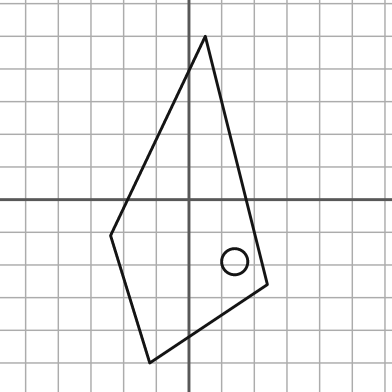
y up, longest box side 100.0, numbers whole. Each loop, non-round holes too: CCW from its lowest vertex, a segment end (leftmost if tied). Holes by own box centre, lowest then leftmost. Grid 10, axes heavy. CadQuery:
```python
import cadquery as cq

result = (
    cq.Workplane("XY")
    .moveTo(-12.0, -50.0)
    .lineTo(24.0, -26.0)
    .lineTo(5.0, 50.0)
    .lineTo(-24.0, -11.0)
    .close()
    .moveTo(14.0, -19.0)
    .circle(4.0)
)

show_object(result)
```